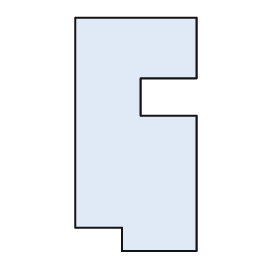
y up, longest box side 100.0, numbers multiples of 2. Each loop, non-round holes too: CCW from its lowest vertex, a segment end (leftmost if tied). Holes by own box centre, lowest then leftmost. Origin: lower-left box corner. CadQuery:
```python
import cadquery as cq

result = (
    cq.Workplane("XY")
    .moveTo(20.0, 0.0)
    .lineTo(52.0, 0.0)
    .lineTo(52.0, 58.0)
    .lineTo(28.0, 58.0)
    .lineTo(28.0, 74.0)
    .lineTo(52.0, 74.0)
    .lineTo(52.0, 100.0)
    .lineTo(0.0, 100.0)
    .lineTo(0.0, 10.0)
    .lineTo(20.0, 10.0)
    .close()
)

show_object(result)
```